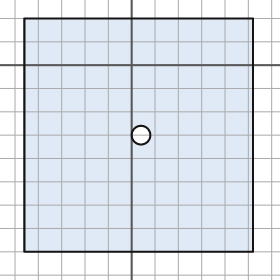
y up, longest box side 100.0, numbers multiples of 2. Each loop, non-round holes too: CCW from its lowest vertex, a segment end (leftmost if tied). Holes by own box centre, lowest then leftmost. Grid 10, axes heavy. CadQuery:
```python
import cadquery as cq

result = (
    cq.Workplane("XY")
    .moveTo(-46.0, -80.0)
    .lineTo(52.0, -80.0)
    .lineTo(52.0, 20.0)
    .lineTo(-46.0, 20.0)
    .close()
    .moveTo(4.0, -30.0)
    .circle(4.0)
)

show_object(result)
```